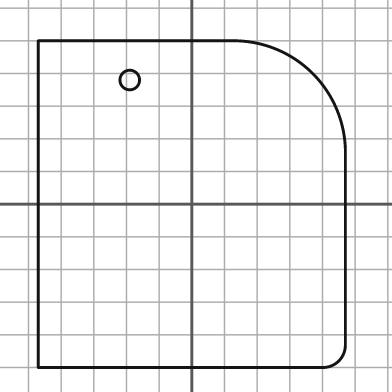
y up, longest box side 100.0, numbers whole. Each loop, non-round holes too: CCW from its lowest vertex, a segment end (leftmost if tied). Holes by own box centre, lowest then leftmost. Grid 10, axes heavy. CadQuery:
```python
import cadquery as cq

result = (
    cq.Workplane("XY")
    .moveTo(-47.0, -50.0)
    .lineTo(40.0, -50.0)
    .threePointArc((45.0, -48.0), (47.0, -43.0))
    .lineTo(47.0, 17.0)
    .threePointArc((37.0, 40.0), (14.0, 50.0))
    .lineTo(-47.0, 50.0)
    .close()
    .moveTo(-19.0, 38.0)
    .circle(3.0)
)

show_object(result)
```